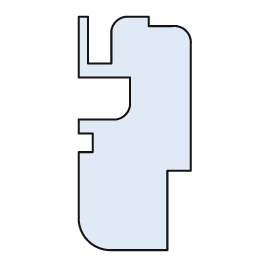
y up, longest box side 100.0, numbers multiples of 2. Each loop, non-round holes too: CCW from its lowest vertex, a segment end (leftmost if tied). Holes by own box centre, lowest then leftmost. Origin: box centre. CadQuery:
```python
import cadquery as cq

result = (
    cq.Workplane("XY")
    .moveTo(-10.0, -50.0)
    .lineTo(14.0, -50.0)
    .lineTo(14.0, -16.0)
    .lineTo(24.0, -16.0)
    .lineTo(24.0, 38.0)
    .threePointArc((22.0, 44.0), (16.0, 46.0))
    .lineTo(6.0, 46.0)
    .lineTo(6.0, 50.0)
    .lineTo(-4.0, 50.0)
    .threePointArc((-8.0, 48.0), (-10.0, 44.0))
    .lineTo(-10.0, 30.0)
    .lineTo(-20.0, 30.0)
    .lineTo(-20.0, 50.0)
    .lineTo(-24.0, 50.0)
    .lineTo(-24.0, 24.0)
    .lineTo(-2.0, 24.0)
    .lineTo(-2.0, 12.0)
    .threePointArc((-4.0, 8.0), (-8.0, 6.0))
    .lineTo(-24.0, 6.0)
    .lineTo(-24.0, 0.0)
    .lineTo(-18.0, 0.0)
    .lineTo(-18.0, -8.0)
    .lineTo(-24.0, -8.0)
    .lineTo(-24.0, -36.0)
    .threePointArc((-20.0, -46.0), (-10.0, -50.0))
    .close()
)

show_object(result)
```